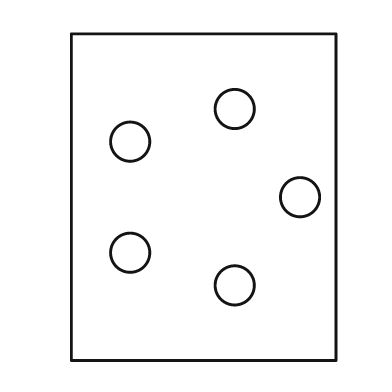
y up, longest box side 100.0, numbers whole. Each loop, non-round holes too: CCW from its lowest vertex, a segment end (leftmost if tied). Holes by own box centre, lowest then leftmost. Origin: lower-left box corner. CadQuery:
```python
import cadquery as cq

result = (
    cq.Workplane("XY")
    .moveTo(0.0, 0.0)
    .lineTo(81.0, 0.0)
    .lineTo(81.0, 100.0)
    .lineTo(0.0, 100.0)
    .close()
    .moveTo(50.0, 23.0)
    .circle(6.0)
    .moveTo(18.0, 33.0)
    .circle(6.0)
    .moveTo(70.0, 50.0)
    .circle(6.0)
    .moveTo(18.0, 67.0)
    .circle(6.0)
    .moveTo(50.0, 77.0)
    .circle(6.0)
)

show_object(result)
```